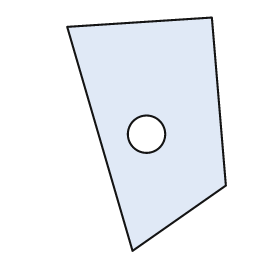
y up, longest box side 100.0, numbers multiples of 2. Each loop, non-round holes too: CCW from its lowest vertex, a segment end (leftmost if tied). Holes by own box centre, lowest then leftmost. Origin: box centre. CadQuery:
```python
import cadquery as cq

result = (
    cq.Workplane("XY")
    .moveTo(-6.0, -50.0)
    .lineTo(34.0, -22.0)
    .lineTo(28.0, 50.0)
    .lineTo(-34.0, 46.0)
    .close()
    .moveTo(0.0, 0.0)
    .circle(8.0)
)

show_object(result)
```